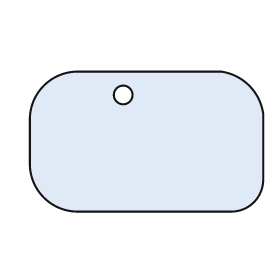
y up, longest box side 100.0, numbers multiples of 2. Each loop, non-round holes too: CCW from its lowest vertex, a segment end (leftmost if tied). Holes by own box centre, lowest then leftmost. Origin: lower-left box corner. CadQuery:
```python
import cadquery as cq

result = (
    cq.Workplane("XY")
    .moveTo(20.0, 0.0)
    .lineTo(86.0, 0.0)
    .threePointArc((96.0, 4.0), (100.0, 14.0))
    .lineTo(100.0, 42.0)
    .threePointArc((94.0, 54.0), (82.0, 60.0))
    .lineTo(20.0, 60.0)
    .threePointArc((6.0, 54.0), (0.0, 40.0))
    .lineTo(0.0, 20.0)
    .threePointArc((6.0, 6.0), (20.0, 0.0))
    .close()
    .moveTo(40.0, 50.0)
    .circle(4.0)
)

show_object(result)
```